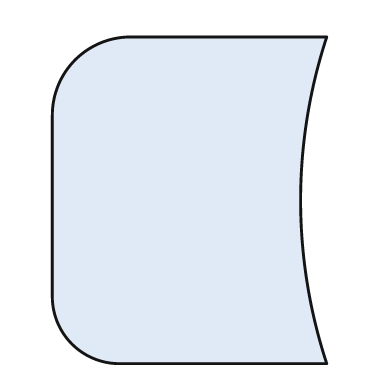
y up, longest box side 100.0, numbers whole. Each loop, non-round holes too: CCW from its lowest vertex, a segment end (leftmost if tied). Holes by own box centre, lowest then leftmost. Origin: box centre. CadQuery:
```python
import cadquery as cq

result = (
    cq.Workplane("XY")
    .moveTo(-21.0, -50.0)
    .lineTo(42.0, -50.0)
    .threePointArc((34.0, 0.0), (42.0, 50.0))
    .lineTo(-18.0, 50.0)
    .threePointArc((-35.0, 43.0), (-42.0, 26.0))
    .lineTo(-42.0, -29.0)
    .threePointArc((-36.0, -44.0), (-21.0, -50.0))
    .close()
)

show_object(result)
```